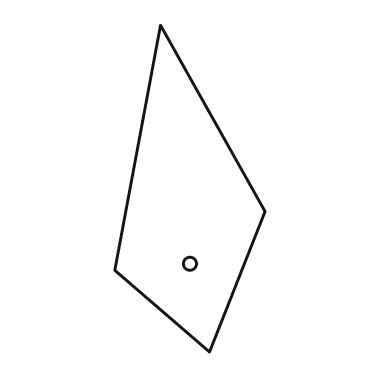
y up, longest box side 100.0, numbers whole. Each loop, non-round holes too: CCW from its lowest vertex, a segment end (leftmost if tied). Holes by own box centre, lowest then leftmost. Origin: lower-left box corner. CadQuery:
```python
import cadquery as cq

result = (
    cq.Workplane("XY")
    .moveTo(29.0, 0.0)
    .lineTo(46.0, 43.0)
    .lineTo(14.0, 100.0)
    .lineTo(0.0, 25.0)
    .close()
    .moveTo(23.0, 27.0)
    .circle(2.0)
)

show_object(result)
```